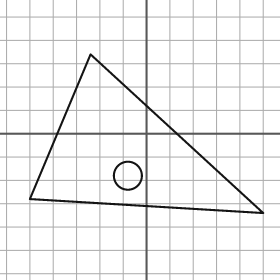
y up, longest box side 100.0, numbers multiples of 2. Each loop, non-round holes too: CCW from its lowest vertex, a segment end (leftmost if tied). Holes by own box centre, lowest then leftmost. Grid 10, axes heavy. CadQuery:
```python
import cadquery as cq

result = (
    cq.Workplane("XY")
    .moveTo(50.0, -34.0)
    .lineTo(-24.0, 34.0)
    .lineTo(-50.0, -28.0)
    .close()
    .moveTo(-8.0, -18.0)
    .circle(6.0)
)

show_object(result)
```